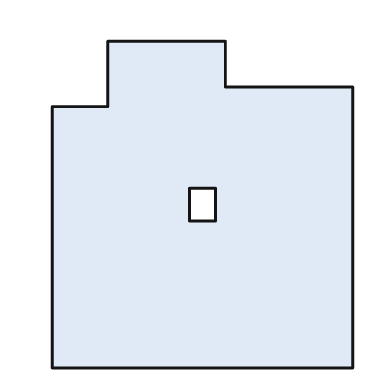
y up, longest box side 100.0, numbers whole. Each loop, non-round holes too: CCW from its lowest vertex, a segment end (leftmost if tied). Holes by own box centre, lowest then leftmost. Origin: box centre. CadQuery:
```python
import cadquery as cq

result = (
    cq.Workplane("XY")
    .moveTo(-46.0, -50.0)
    .lineTo(46.0, -50.0)
    .lineTo(46.0, 36.0)
    .lineTo(7.0, 36.0)
    .lineTo(7.0, 50.0)
    .lineTo(-29.0, 50.0)
    .lineTo(-29.0, 30.0)
    .lineTo(-46.0, 30.0)
    .close()
    .moveTo(-4.0, -5.0)
    .lineTo(4.0, -5.0)
    .lineTo(4.0, 5.0)
    .lineTo(-4.0, 5.0)
    .close()
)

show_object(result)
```